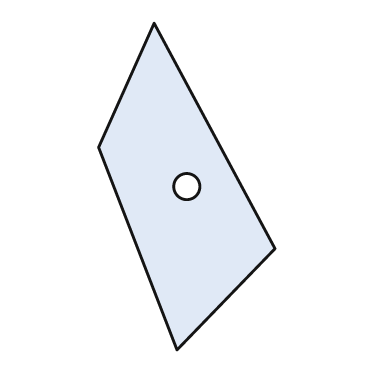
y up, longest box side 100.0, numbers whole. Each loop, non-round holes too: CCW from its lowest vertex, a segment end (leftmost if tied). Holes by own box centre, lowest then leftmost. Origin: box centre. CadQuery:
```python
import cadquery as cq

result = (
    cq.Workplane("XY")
    .moveTo(-3.0, -50.0)
    .lineTo(27.0, -19.0)
    .lineTo(-10.0, 50.0)
    .lineTo(-27.0, 12.0)
    .close()
    .moveTo(0.0, 0.0)
    .circle(4.0)
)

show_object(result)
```